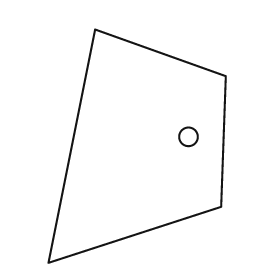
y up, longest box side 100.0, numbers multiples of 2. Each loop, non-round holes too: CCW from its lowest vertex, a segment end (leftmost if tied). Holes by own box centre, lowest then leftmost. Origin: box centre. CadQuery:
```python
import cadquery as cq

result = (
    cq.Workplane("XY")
    .moveTo(-38.0, -50.0)
    .lineTo(36.0, -26.0)
    .lineTo(38.0, 30.0)
    .lineTo(-18.0, 50.0)
    .close()
    .moveTo(22.0, 4.0)
    .circle(4.0)
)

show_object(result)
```